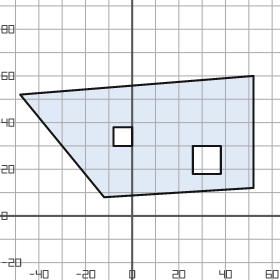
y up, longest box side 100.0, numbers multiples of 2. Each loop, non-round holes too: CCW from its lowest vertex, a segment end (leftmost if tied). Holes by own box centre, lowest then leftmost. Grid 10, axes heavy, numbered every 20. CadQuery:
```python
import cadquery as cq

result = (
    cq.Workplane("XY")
    .moveTo(-12.0, 8.0)
    .lineTo(52.0, 12.0)
    .lineTo(52.0, 60.0)
    .lineTo(-48.0, 52.0)
    .close()
    .moveTo(26.0, 18.0)
    .lineTo(38.0, 18.0)
    .lineTo(38.0, 30.0)
    .lineTo(26.0, 30.0)
    .close()
    .moveTo(-8.0, 30.0)
    .lineTo(0.0, 30.0)
    .lineTo(0.0, 38.0)
    .lineTo(-8.0, 38.0)
    .close()
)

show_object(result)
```